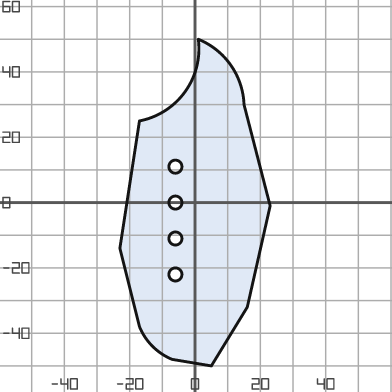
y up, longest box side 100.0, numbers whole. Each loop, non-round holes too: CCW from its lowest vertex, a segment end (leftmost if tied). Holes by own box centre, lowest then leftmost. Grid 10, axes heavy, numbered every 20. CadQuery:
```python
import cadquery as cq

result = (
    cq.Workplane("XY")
    .moveTo(5.0, -50.0)
    .lineTo(16.0, -32.0)
    .lineTo(23.0, -1.0)
    .lineTo(15.0, 30.0)
    .threePointArc((11.0, 42.0), (1.0, 50.0))
    .threePointArc((-3.0, 34.0), (-17.0, 25.0))
    .lineTo(-23.0, -14.0)
    .lineTo(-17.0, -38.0)
    .threePointArc((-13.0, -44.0), (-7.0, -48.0))
    .close()
    .moveTo(-6.0, -22.0)
    .circle(2.0)
    .moveTo(-6.0, -11.0)
    .circle(2.0)
    .moveTo(-6.0, 0.0)
    .circle(2.0)
    .moveTo(-6.0, 11.0)
    .circle(2.0)
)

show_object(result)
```